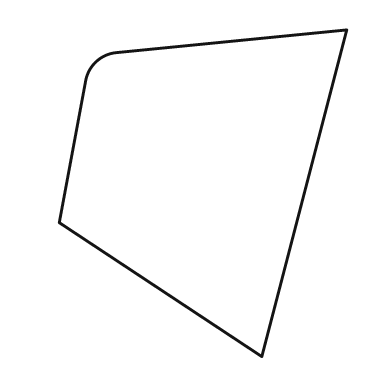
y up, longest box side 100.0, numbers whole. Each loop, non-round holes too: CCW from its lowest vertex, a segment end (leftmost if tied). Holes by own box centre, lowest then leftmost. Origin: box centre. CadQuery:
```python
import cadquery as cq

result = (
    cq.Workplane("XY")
    .moveTo(18.0, -50.0)
    .lineTo(44.0, 50.0)
    .lineTo(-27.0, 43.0)
    .threePointArc((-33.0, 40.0), (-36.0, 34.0))
    .lineTo(-44.0, -9.0)
    .close()
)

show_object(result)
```